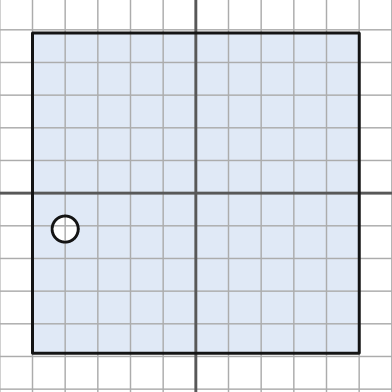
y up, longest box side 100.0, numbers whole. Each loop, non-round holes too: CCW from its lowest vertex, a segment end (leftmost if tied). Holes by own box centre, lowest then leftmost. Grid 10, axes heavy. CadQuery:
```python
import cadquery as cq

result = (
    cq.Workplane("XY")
    .moveTo(-50.0, -49.0)
    .lineTo(50.0, -49.0)
    .lineTo(50.0, 49.0)
    .lineTo(-50.0, 49.0)
    .close()
    .moveTo(-40.0, -11.0)
    .circle(4.0)
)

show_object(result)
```